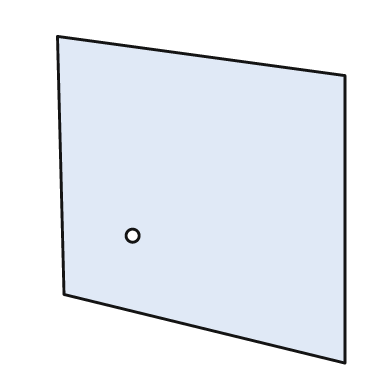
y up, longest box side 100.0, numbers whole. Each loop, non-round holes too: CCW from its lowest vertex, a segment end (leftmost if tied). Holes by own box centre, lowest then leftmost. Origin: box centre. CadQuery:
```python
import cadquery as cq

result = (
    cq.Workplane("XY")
    .moveTo(44.0, -50.0)
    .lineTo(44.0, 38.0)
    .lineTo(-44.0, 50.0)
    .lineTo(-42.0, -29.0)
    .close()
    .moveTo(-21.0, -11.0)
    .circle(2.0)
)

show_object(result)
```